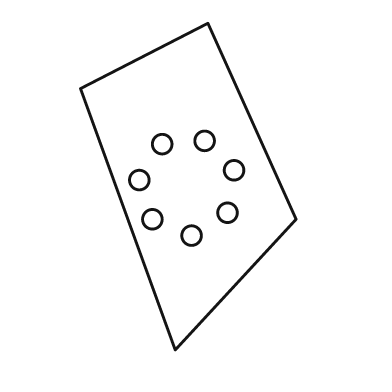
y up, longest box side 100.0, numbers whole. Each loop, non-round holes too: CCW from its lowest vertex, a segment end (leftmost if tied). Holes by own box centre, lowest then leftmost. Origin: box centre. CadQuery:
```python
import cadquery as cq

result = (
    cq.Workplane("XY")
    .moveTo(-4.0, -50.0)
    .lineTo(33.0, -10.0)
    .lineTo(6.0, 50.0)
    .lineTo(-33.0, 30.0)
    .close()
    .moveTo(1.0, -15.0)
    .circle(3.0)
    .moveTo(-11.0, -10.0)
    .circle(3.0)
    .moveTo(12.0, -8.0)
    .circle(3.0)
    .moveTo(-15.0, 2.0)
    .circle(3.0)
    .moveTo(14.0, 5.0)
    .circle(3.0)
    .moveTo(-8.0, 13.0)
    .circle(3.0)
    .moveTo(5.0, 14.0)
    .circle(3.0)
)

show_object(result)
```